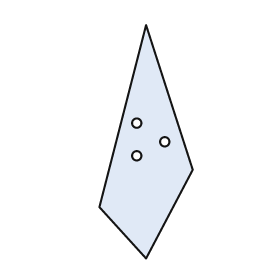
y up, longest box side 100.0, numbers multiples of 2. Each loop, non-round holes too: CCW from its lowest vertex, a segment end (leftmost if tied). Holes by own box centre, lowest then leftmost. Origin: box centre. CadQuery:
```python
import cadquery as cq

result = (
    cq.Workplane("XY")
    .moveTo(0.0, -50.0)
    .lineTo(20.0, -12.0)
    .lineTo(0.0, 50.0)
    .lineTo(-20.0, -28.0)
    .close()
    .moveTo(-4.0, -6.0)
    .circle(2.0)
    .moveTo(8.0, 0.0)
    .circle(2.0)
    .moveTo(-4.0, 8.0)
    .circle(2.0)
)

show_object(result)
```